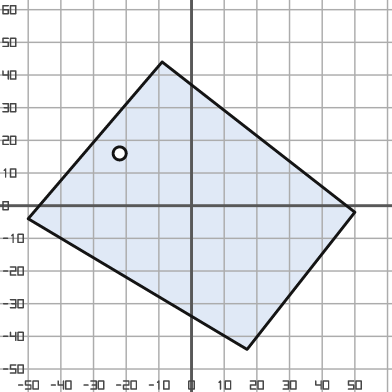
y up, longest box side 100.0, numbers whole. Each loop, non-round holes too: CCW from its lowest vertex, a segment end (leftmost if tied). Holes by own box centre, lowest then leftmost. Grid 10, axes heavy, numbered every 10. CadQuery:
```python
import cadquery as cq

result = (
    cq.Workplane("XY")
    .moveTo(17.0, -44.0)
    .lineTo(50.0, -2.0)
    .lineTo(-9.0, 44.0)
    .lineTo(-50.0, -4.0)
    .close()
    .moveTo(-22.0, 16.0)
    .circle(2.0)
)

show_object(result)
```